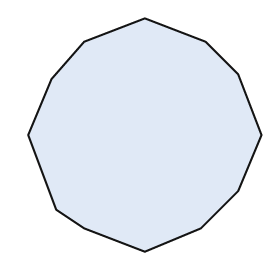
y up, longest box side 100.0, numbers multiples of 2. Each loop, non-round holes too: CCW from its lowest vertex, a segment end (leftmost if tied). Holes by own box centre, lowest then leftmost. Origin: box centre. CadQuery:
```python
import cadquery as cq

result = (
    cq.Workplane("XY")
    .moveTo(0.0, -50.0)
    .lineTo(24.0, -40.0)
    .lineTo(40.0, -24.0)
    .lineTo(50.0, 0.0)
    .lineTo(40.0, 26.0)
    .lineTo(26.0, 40.0)
    .lineTo(0.0, 50.0)
    .lineTo(-26.0, 40.0)
    .lineTo(-40.0, 24.0)
    .lineTo(-50.0, 0.0)
    .lineTo(-38.0, -32.0)
    .lineTo(-26.0, -40.0)
    .close()
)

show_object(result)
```